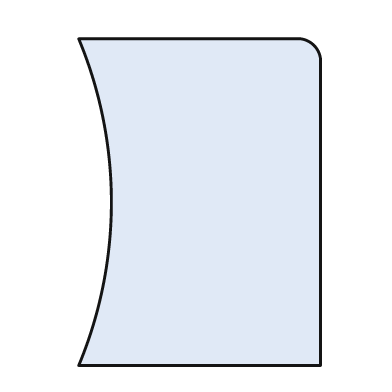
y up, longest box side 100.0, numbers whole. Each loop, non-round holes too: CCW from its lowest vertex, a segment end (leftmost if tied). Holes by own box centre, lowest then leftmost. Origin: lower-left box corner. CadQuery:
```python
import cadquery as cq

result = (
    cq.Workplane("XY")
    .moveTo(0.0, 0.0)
    .lineTo(74.0, 0.0)
    .lineTo(74.0, 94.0)
    .threePointArc((72.0, 98.0), (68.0, 100.0))
    .lineTo(0.0, 100.0)
    .threePointArc((10.0, 50.0), (0.0, 0.0))
    .close()
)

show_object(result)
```